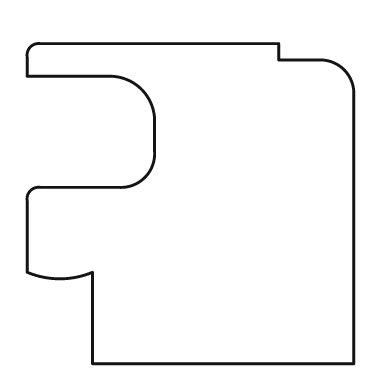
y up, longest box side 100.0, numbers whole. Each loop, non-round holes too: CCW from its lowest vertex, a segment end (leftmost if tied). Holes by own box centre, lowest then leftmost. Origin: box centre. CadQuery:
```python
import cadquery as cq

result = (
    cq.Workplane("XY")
    .moveTo(-30.0, -49.0)
    .lineTo(50.0, -49.0)
    .lineTo(50.0, 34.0)
    .threePointArc((47.0, 41.0), (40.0, 44.0))
    .lineTo(27.0, 44.0)
    .lineTo(27.0, 49.0)
    .lineTo(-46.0, 49.0)
    .threePointArc((-49.0, 48.0), (-50.0, 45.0))
    .lineTo(-50.0, 39.0)
    .lineTo(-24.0, 39.0)
    .threePointArc((-15.0, 35.0), (-11.0, 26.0))
    .lineTo(-11.0, 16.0)
    .threePointArc((-14.0, 8.0), (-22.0, 5.0))
    .lineTo(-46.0, 5.0)
    .threePointArc((-49.0, 4.0), (-50.0, 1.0))
    .lineTo(-50.0, -21.0)
    .threePointArc((-40.0, -23.0), (-30.0, -21.0))
    .close()
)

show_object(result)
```